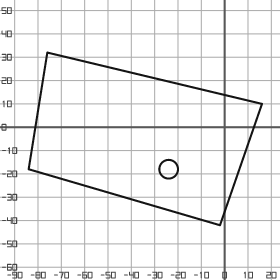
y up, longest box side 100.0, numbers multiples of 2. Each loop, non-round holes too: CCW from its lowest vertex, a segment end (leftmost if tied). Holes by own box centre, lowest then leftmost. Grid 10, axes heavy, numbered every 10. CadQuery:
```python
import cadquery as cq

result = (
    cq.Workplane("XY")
    .moveTo(-2.0, -42.0)
    .lineTo(16.0, 10.0)
    .lineTo(-76.0, 32.0)
    .lineTo(-84.0, -18.0)
    .close()
    .moveTo(-24.0, -18.0)
    .circle(4.0)
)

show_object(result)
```